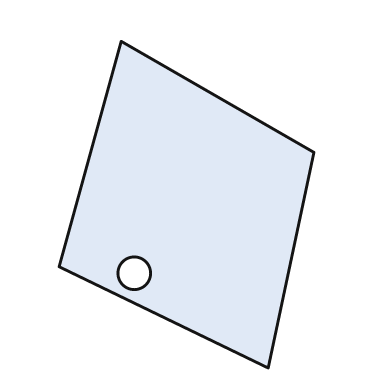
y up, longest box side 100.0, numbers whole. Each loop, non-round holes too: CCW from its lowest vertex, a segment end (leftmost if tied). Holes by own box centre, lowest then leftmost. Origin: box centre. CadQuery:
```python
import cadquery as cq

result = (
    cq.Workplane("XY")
    .moveTo(25.0, -50.0)
    .lineTo(39.0, 16.0)
    .lineTo(-20.0, 50.0)
    .lineTo(-39.0, -19.0)
    .close()
    .moveTo(-16.0, -21.0)
    .circle(5.0)
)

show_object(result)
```